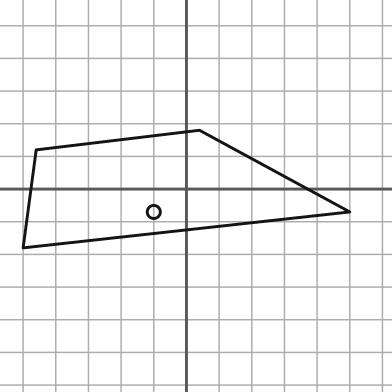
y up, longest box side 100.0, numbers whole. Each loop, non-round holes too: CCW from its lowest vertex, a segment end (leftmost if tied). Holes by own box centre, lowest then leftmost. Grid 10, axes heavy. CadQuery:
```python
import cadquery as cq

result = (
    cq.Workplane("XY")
    .moveTo(-50.0, -18.0)
    .lineTo(50.0, -7.0)
    .lineTo(4.0, 18.0)
    .lineTo(-46.0, 12.0)
    .close()
    .moveTo(-10.0, -7.0)
    .circle(2.0)
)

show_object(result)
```